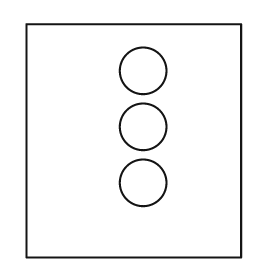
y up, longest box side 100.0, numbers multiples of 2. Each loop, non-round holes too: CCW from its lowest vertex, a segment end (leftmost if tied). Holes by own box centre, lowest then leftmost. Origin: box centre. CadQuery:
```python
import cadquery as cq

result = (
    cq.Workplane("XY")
    .moveTo(-46.0, -50.0)
    .lineTo(46.0, -50.0)
    .lineTo(46.0, 50.0)
    .lineTo(-46.0, 50.0)
    .close()
    .moveTo(4.0, -18.0)
    .circle(10.0)
    .moveTo(4.0, 6.0)
    .circle(10.0)
    .moveTo(4.0, 30.0)
    .circle(10.0)
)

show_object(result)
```